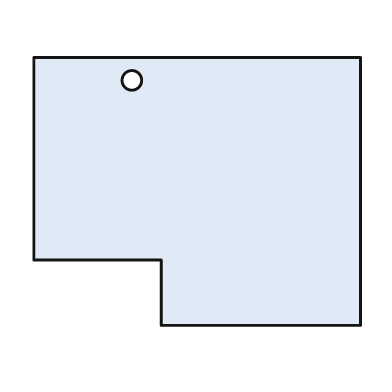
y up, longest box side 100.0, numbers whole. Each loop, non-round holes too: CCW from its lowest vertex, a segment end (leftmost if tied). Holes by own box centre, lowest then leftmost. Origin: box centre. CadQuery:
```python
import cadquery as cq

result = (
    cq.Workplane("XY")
    .moveTo(-11.0, -41.0)
    .lineTo(50.0, -41.0)
    .lineTo(50.0, 41.0)
    .lineTo(-50.0, 41.0)
    .lineTo(-50.0, -21.0)
    .lineTo(-11.0, -21.0)
    .close()
    .moveTo(-20.0, 34.0)
    .circle(3.0)
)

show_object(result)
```